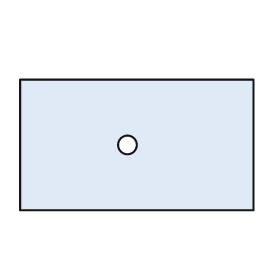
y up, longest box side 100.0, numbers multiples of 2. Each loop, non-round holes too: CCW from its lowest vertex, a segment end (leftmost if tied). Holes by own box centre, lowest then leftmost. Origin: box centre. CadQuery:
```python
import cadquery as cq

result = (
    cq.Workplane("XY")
    .moveTo(-50.0, -28.0)
    .lineTo(50.0, -28.0)
    .lineTo(50.0, 28.0)
    .lineTo(-50.0, 28.0)
    .close()
    .moveTo(-4.0, 0.0)
    .circle(4.0)
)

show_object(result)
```